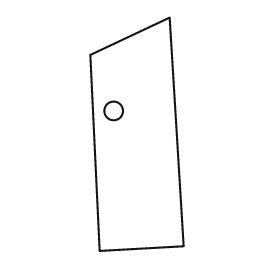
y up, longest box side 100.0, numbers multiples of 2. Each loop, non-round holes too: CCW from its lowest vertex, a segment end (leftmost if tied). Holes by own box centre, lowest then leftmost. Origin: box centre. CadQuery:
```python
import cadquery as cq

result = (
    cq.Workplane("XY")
    .moveTo(-16.0, -50.0)
    .lineTo(20.0, -48.0)
    .lineTo(14.0, 50.0)
    .lineTo(-20.0, 34.0)
    .close()
    .moveTo(-10.0, 10.0)
    .circle(4.0)
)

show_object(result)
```